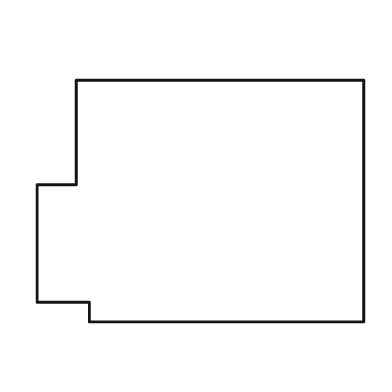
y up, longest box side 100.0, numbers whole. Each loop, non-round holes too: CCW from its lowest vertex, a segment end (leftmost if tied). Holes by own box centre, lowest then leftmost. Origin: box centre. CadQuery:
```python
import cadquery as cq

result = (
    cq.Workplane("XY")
    .moveTo(-34.0, -37.0)
    .lineTo(50.0, -37.0)
    .lineTo(50.0, 37.0)
    .lineTo(-38.0, 37.0)
    .lineTo(-38.0, 5.0)
    .lineTo(-50.0, 5.0)
    .lineTo(-50.0, -31.0)
    .lineTo(-34.0, -31.0)
    .close()
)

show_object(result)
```